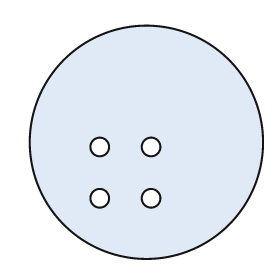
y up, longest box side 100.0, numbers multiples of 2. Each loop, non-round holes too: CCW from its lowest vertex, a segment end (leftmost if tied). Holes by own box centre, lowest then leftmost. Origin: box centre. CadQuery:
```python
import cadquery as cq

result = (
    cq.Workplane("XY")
    .moveTo(0.0, 0.0)
    .circle(50.0)
    .moveTo(-20.0, -24.0)
    .circle(4.0)
    .moveTo(2.0, -24.0)
    .circle(4.0)
    .moveTo(-20.0, -2.0)
    .circle(4.0)
    .moveTo(2.0, -2.0)
    .circle(4.0)
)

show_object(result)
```